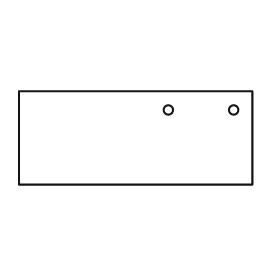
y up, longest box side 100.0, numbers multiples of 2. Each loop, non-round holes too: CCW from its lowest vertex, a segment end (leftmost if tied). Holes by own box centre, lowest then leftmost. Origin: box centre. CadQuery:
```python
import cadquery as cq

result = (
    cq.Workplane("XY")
    .moveTo(-50.0, -20.0)
    .lineTo(50.0, -20.0)
    .lineTo(50.0, 20.0)
    .lineTo(-50.0, 20.0)
    .close()
    .moveTo(14.0, 12.0)
    .circle(2.0)
    .moveTo(42.0, 12.0)
    .circle(2.0)
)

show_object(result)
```